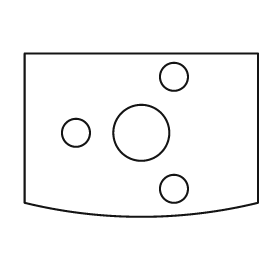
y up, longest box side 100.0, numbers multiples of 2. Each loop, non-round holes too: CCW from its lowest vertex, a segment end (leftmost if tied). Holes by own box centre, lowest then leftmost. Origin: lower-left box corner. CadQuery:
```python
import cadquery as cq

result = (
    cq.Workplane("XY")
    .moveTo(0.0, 6.0)
    .threePointArc((50.0, 0.0), (100.0, 6.0))
    .lineTo(100.0, 70.0)
    .lineTo(0.0, 70.0)
    .close()
    .moveTo(64.0, 12.0)
    .circle(6.0)
    .moveTo(22.0, 36.0)
    .circle(6.0)
    .moveTo(50.0, 36.0)
    .circle(12.0)
    .moveTo(64.0, 60.0)
    .circle(6.0)
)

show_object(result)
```